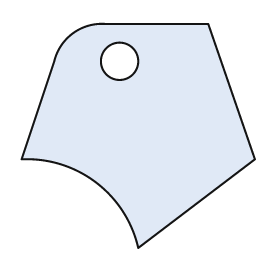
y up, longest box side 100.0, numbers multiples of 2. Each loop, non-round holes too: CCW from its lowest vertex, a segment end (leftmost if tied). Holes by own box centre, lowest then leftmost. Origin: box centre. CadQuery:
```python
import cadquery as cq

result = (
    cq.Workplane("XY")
    .moveTo(0.0, -48.0)
    .lineTo(50.0, -10.0)
    .lineTo(30.0, 48.0)
    .lineTo(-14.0, 48.0)
    .threePointArc((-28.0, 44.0), (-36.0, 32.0))
    .lineTo(-50.0, -10.0)
    .threePointArc((-18.0, -20.0), (0.0, -48.0))
    .close()
    .moveTo(-8.0, 32.0)
    .circle(8.0)
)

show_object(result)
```